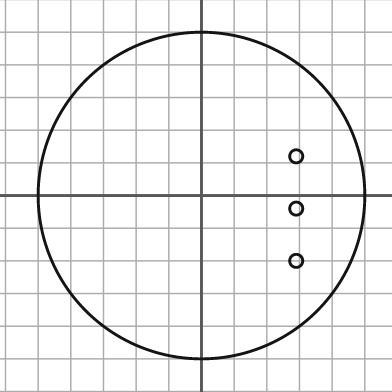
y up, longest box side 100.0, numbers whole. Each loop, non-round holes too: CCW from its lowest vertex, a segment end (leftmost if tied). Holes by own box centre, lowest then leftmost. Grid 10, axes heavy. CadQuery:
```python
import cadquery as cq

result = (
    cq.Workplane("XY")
    .moveTo(0.0, 0.0)
    .circle(50.0)
    .moveTo(29.0, -20.0)
    .circle(2.0)
    .moveTo(29.0, -4.0)
    .circle(2.0)
    .moveTo(29.0, 12.0)
    .circle(2.0)
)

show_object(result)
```